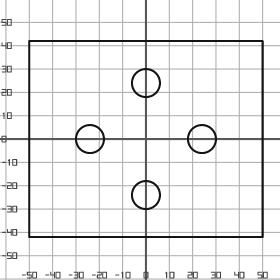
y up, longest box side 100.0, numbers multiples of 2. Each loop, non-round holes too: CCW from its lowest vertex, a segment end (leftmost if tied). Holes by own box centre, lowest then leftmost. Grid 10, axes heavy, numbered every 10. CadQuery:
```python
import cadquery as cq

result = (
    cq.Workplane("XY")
    .moveTo(-50.0, -42.0)
    .lineTo(50.0, -42.0)
    .lineTo(50.0, 42.0)
    .lineTo(-50.0, 42.0)
    .close()
    .moveTo(0.0, -24.0)
    .circle(6.0)
    .moveTo(-24.0, 0.0)
    .circle(6.0)
    .moveTo(24.0, 0.0)
    .circle(6.0)
    .moveTo(0.0, 24.0)
    .circle(6.0)
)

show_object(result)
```